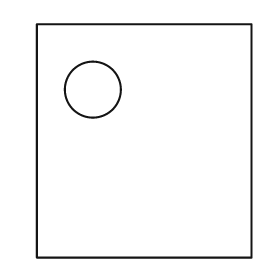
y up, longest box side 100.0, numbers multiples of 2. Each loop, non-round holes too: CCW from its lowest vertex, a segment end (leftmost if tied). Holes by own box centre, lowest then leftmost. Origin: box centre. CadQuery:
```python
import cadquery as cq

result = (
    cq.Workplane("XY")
    .moveTo(-46.0, -50.0)
    .lineTo(46.0, -50.0)
    .lineTo(46.0, 50.0)
    .lineTo(-46.0, 50.0)
    .close()
    .moveTo(-22.0, 22.0)
    .circle(12.0)
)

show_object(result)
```